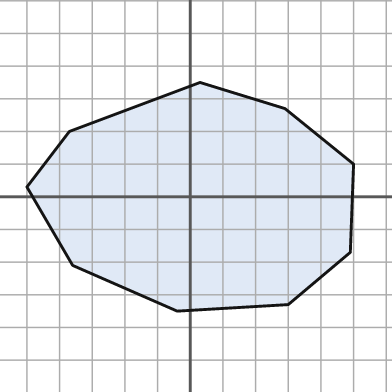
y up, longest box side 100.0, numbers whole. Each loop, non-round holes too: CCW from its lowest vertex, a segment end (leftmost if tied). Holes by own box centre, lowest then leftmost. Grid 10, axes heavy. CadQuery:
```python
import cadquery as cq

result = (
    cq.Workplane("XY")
    .moveTo(-4.0, -35.0)
    .lineTo(30.0, -33.0)
    .lineTo(49.0, -17.0)
    .lineTo(50.0, 10.0)
    .lineTo(29.0, 27.0)
    .lineTo(3.0, 35.0)
    .lineTo(-37.0, 20.0)
    .lineTo(-50.0, 3.0)
    .lineTo(-36.0, -21.0)
    .close()
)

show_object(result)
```